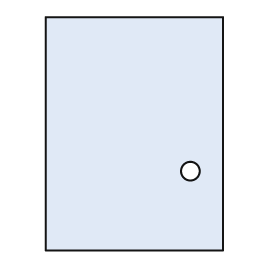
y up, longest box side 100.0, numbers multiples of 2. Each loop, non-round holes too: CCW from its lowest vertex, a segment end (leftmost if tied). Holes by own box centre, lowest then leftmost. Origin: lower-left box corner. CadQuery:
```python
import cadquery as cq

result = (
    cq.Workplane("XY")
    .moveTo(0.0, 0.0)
    .lineTo(76.0, 0.0)
    .lineTo(76.0, 100.0)
    .lineTo(0.0, 100.0)
    .close()
    .moveTo(62.0, 34.0)
    .circle(4.0)
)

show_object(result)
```